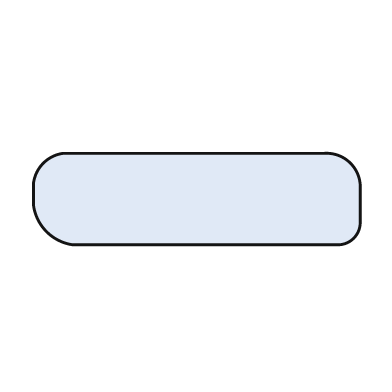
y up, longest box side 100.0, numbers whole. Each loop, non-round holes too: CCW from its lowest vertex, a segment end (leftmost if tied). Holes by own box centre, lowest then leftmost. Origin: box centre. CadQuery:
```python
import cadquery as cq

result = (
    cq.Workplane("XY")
    .moveTo(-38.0, -14.0)
    .lineTo(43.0, -14.0)
    .threePointArc((48.0, -12.0), (50.0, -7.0))
    .lineTo(50.0, 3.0)
    .threePointArc((47.0, 11.0), (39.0, 14.0))
    .lineTo(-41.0, 14.0)
    .threePointArc((-47.0, 11.0), (-50.0, 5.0))
    .lineTo(-50.0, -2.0)
    .threePointArc((-46.0, -10.0), (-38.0, -14.0))
    .close()
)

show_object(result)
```